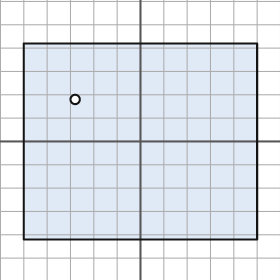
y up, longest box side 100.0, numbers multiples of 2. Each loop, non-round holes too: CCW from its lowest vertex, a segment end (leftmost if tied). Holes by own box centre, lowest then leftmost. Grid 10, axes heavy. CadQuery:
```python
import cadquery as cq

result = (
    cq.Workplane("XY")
    .moveTo(-50.0, -42.0)
    .lineTo(50.0, -42.0)
    .lineTo(50.0, 42.0)
    .lineTo(-50.0, 42.0)
    .close()
    .moveTo(-28.0, 18.0)
    .circle(2.0)
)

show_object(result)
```